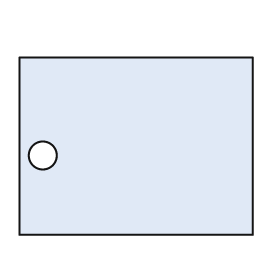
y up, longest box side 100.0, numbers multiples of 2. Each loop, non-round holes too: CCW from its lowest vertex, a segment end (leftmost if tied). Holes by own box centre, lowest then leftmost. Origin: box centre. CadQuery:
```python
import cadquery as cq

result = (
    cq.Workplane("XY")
    .moveTo(-50.0, -38.0)
    .lineTo(50.0, -38.0)
    .lineTo(50.0, 38.0)
    .lineTo(-50.0, 38.0)
    .close()
    .moveTo(-40.0, -4.0)
    .circle(6.0)
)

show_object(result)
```